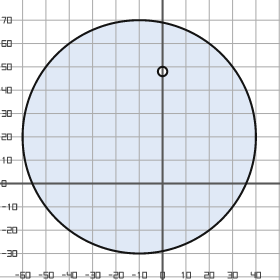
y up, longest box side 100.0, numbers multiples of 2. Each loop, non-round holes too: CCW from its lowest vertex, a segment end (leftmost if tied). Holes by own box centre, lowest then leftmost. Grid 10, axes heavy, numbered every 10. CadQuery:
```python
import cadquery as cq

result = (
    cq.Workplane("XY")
    .moveTo(-10.0, 20.0)
    .circle(50.0)
    .moveTo(0.0, 48.0)
    .circle(2.0)
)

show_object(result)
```